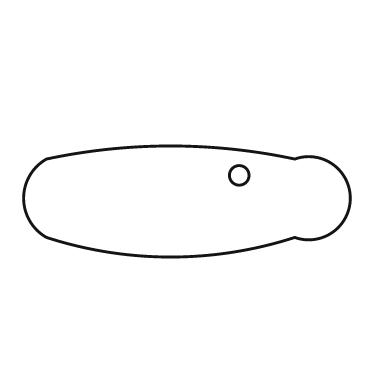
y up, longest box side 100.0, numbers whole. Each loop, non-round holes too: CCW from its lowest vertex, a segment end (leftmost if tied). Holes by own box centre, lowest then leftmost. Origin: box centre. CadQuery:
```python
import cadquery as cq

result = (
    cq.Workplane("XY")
    .moveTo(-43.0, -11.0)
    .threePointArc((-5.0, -17.0), (33.0, -11.0))
    .threePointArc((50.0, 1.0), (33.0, 13.0))
    .threePointArc((-5.0, 17.0), (-43.0, 13.0))
    .threePointArc((-50.0, 1.0), (-43.0, -11.0))
    .close()
    .moveTo(16.0, 8.0)
    .circle(3.0)
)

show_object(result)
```